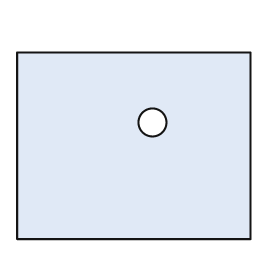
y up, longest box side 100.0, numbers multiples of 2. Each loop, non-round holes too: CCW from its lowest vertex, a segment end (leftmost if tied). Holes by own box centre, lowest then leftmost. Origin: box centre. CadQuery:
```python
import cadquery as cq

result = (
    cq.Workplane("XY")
    .moveTo(-50.0, -40.0)
    .lineTo(50.0, -40.0)
    .lineTo(50.0, 40.0)
    .lineTo(-50.0, 40.0)
    .close()
    .moveTo(8.0, 10.0)
    .circle(6.0)
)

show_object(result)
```